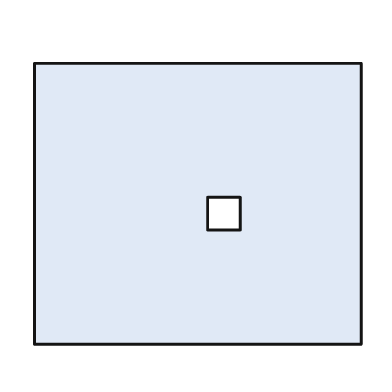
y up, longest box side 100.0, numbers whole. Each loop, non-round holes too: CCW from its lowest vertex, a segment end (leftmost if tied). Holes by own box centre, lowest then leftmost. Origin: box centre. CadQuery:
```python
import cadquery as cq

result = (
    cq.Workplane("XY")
    .moveTo(-50.0, -43.0)
    .lineTo(50.0, -43.0)
    .lineTo(50.0, 43.0)
    .lineTo(-50.0, 43.0)
    .close()
    .moveTo(3.0, -8.0)
    .lineTo(13.0, -8.0)
    .lineTo(13.0, 2.0)
    .lineTo(3.0, 2.0)
    .close()
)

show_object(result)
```